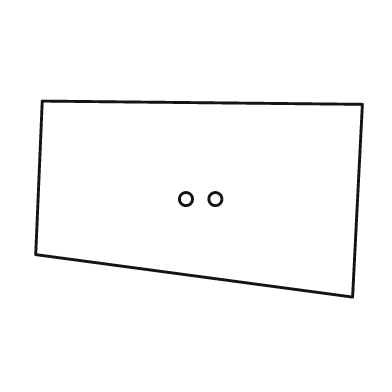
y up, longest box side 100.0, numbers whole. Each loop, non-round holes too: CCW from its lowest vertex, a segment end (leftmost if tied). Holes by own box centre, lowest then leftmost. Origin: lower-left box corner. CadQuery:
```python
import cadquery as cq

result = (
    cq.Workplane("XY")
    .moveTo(97.0, 0.0)
    .lineTo(100.0, 59.0)
    .lineTo(2.0, 60.0)
    .lineTo(0.0, 13.0)
    .close()
    .moveTo(46.0, 30.0)
    .circle(2.0)
    .moveTo(55.0, 30.0)
    .circle(2.0)
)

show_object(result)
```